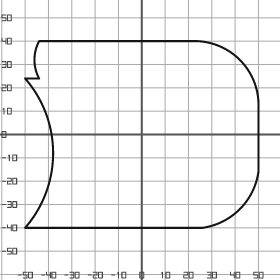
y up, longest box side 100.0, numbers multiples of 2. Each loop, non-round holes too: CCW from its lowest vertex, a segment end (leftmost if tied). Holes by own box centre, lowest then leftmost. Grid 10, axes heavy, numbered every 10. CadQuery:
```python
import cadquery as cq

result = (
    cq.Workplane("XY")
    .moveTo(-50.0, -40.0)
    .lineTo(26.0, -40.0)
    .threePointArc((42.0, -32.0), (50.0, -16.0))
    .lineTo(50.0, 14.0)
    .threePointArc((42.0, 32.0), (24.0, 40.0))
    .lineTo(-44.0, 40.0)
    .threePointArc((-46.0, 32.0), (-44.0, 24.0))
    .lineTo(-50.0, 24.0)
    .threePointArc((-38.0, -8.0), (-50.0, -40.0))
    .close()
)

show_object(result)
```